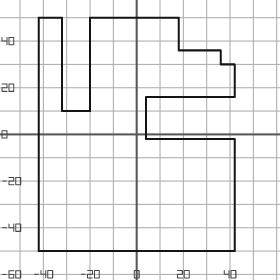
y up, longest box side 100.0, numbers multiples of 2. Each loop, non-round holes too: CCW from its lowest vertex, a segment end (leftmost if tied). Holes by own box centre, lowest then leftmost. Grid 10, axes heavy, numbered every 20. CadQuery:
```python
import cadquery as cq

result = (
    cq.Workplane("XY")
    .moveTo(-42.0, -50.0)
    .lineTo(42.0, -50.0)
    .lineTo(42.0, -2.0)
    .lineTo(4.0, -2.0)
    .lineTo(4.0, 16.0)
    .lineTo(42.0, 16.0)
    .lineTo(42.0, 30.0)
    .lineTo(36.0, 30.0)
    .lineTo(36.0, 36.0)
    .lineTo(18.0, 36.0)
    .lineTo(18.0, 50.0)
    .lineTo(-20.0, 50.0)
    .lineTo(-20.0, 10.0)
    .lineTo(-32.0, 10.0)
    .lineTo(-32.0, 50.0)
    .lineTo(-42.0, 50.0)
    .close()
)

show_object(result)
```